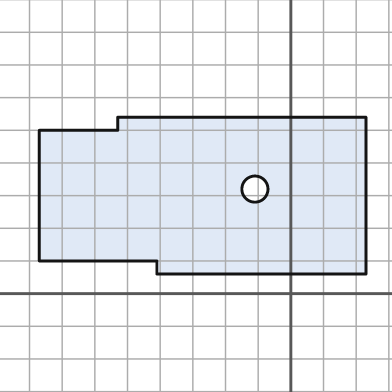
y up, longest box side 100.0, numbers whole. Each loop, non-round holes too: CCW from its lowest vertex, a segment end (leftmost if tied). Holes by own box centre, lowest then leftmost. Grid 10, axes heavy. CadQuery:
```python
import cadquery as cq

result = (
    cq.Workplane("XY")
    .moveTo(-41.0, 6.0)
    .lineTo(23.0, 6.0)
    .lineTo(23.0, 54.0)
    .lineTo(-53.0, 54.0)
    .lineTo(-53.0, 50.0)
    .lineTo(-77.0, 50.0)
    .lineTo(-77.0, 10.0)
    .lineTo(-41.0, 10.0)
    .close()
    .moveTo(-11.0, 32.0)
    .circle(4.0)
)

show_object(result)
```